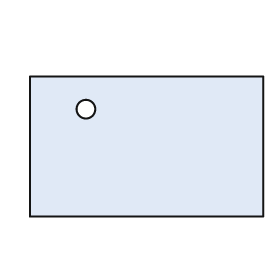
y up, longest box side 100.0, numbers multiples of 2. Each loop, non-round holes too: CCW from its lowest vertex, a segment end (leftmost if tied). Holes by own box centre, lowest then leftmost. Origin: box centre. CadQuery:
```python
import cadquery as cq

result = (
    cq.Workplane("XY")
    .moveTo(-50.0, -30.0)
    .lineTo(50.0, -30.0)
    .lineTo(50.0, 30.0)
    .lineTo(-50.0, 30.0)
    .close()
    .moveTo(-26.0, 16.0)
    .circle(4.0)
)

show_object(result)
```